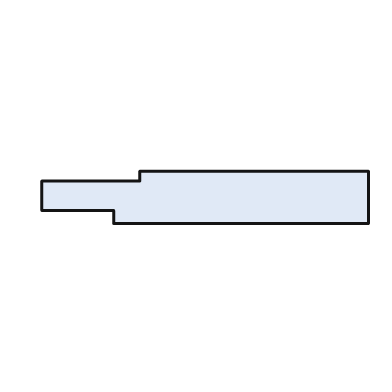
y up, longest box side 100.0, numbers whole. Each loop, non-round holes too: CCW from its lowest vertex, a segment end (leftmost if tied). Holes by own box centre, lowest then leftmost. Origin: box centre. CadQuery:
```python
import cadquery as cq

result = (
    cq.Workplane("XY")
    .moveTo(-28.0, -8.0)
    .lineTo(50.0, -8.0)
    .lineTo(50.0, 8.0)
    .lineTo(-20.0, 8.0)
    .lineTo(-20.0, 5.0)
    .lineTo(-50.0, 5.0)
    .lineTo(-50.0, -4.0)
    .lineTo(-28.0, -4.0)
    .close()
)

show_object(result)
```